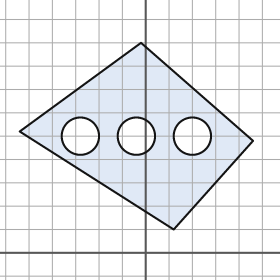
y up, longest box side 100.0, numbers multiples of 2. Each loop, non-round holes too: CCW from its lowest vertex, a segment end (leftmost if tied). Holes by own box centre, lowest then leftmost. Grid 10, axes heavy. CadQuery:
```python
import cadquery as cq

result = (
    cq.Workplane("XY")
    .moveTo(12.0, 10.0)
    .lineTo(46.0, 48.0)
    .lineTo(-2.0, 90.0)
    .lineTo(-54.0, 52.0)
    .close()
    .moveTo(-28.0, 50.0)
    .circle(8.0)
    .moveTo(-4.0, 50.0)
    .circle(8.0)
    .moveTo(20.0, 50.0)
    .circle(8.0)
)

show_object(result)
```